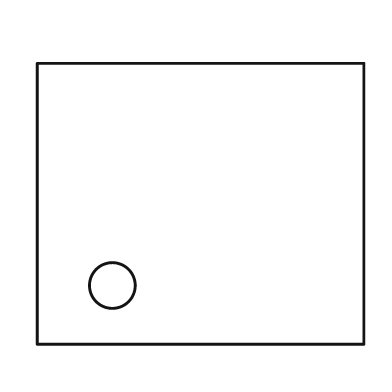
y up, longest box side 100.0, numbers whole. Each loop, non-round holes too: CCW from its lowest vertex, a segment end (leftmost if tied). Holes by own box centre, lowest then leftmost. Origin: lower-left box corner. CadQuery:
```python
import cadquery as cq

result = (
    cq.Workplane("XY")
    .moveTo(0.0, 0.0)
    .lineTo(100.0, 0.0)
    .lineTo(100.0, 86.0)
    .lineTo(0.0, 86.0)
    .close()
    .moveTo(23.0, 18.0)
    .circle(7.0)
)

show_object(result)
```